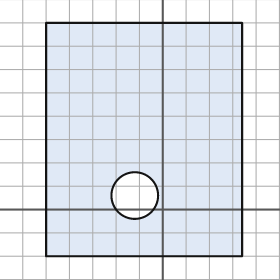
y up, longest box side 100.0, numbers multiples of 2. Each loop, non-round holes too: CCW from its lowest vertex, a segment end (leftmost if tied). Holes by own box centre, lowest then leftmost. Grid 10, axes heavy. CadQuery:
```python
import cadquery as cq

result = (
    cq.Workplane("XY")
    .moveTo(-50.0, -20.0)
    .lineTo(34.0, -20.0)
    .lineTo(34.0, 80.0)
    .lineTo(-50.0, 80.0)
    .close()
    .moveTo(-12.0, 6.0)
    .circle(10.0)
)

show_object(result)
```